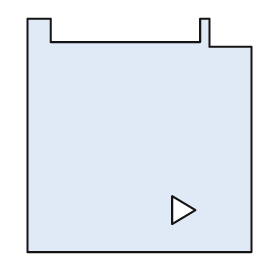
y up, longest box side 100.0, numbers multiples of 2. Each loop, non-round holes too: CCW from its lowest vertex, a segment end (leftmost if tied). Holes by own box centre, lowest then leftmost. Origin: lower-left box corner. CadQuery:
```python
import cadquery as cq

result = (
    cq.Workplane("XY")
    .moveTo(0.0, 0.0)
    .lineTo(96.0, 0.0)
    .lineTo(96.0, 88.0)
    .lineTo(78.0, 88.0)
    .lineTo(78.0, 100.0)
    .lineTo(74.0, 100.0)
    .lineTo(74.0, 90.0)
    .lineTo(10.0, 90.0)
    .lineTo(10.0, 100.0)
    .lineTo(0.0, 100.0)
    .close()
    .moveTo(62.0, 12.0)
    .lineTo(72.0, 18.0)
    .lineTo(62.0, 24.0)
    .close()
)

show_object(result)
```